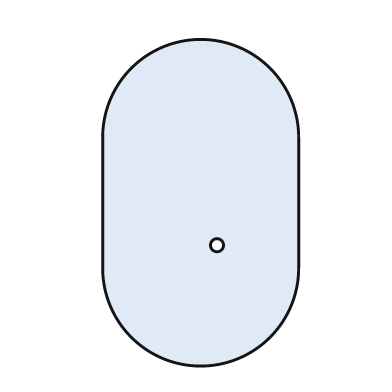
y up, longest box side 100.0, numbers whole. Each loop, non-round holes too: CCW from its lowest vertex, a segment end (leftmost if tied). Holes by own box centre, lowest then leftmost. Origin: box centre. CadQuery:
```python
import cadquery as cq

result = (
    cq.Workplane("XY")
    .moveTo(-30.0, -20.0)
    .threePointArc((0.0, -50.0), (30.0, -20.0))
    .lineTo(30.0, 20.0)
    .threePointArc((0.0, 50.0), (-30.0, 20.0))
    .close()
    .moveTo(5.0, -13.0)
    .circle(2.0)
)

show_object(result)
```